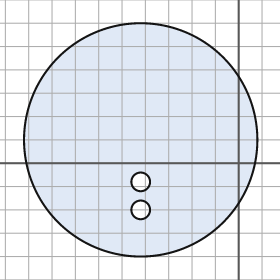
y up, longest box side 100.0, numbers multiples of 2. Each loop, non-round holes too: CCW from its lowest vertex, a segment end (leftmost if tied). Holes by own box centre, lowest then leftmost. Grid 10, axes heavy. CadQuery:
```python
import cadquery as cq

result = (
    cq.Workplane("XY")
    .moveTo(-42.0, 10.0)
    .circle(50.0)
    .moveTo(-42.0, -20.0)
    .circle(4.0)
    .moveTo(-42.0, -8.0)
    .circle(4.0)
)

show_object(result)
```